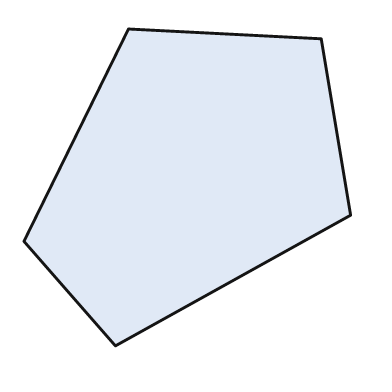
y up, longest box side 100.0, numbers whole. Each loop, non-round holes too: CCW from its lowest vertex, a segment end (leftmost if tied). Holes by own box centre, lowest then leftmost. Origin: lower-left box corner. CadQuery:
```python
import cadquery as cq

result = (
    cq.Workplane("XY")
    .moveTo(28.0, 0.0)
    .lineTo(100.0, 40.0)
    .lineTo(91.0, 94.0)
    .lineTo(32.0, 97.0)
    .lineTo(0.0, 32.0)
    .close()
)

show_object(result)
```